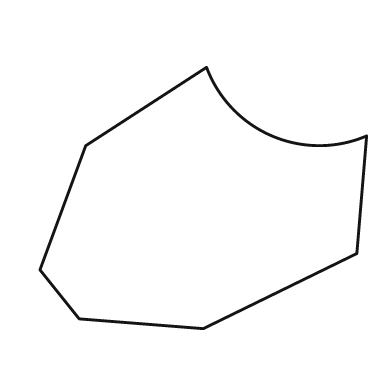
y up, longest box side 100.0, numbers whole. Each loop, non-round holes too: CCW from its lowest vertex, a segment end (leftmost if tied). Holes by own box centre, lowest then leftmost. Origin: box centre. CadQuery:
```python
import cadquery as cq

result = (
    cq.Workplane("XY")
    .moveTo(0.0, -40.0)
    .lineTo(47.0, -17.0)
    .lineTo(50.0, 19.0)
    .threePointArc((21.0, 19.0), (1.0, 40.0))
    .lineTo(-36.0, 16.0)
    .lineTo(-50.0, -22.0)
    .lineTo(-38.0, -37.0)
    .close()
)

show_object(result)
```